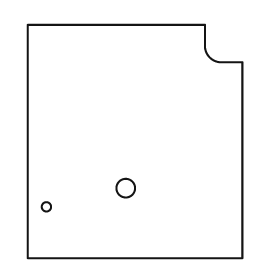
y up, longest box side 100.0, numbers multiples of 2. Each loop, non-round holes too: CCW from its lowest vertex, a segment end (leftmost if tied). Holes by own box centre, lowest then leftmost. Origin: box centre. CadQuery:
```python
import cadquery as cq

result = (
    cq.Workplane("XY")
    .moveTo(-46.0, -50.0)
    .lineTo(46.0, -50.0)
    .lineTo(46.0, 34.0)
    .lineTo(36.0, 34.0)
    .threePointArc((32.0, 36.0), (30.0, 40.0))
    .lineTo(30.0, 50.0)
    .lineTo(-46.0, 50.0)
    .close()
    .moveTo(-38.0, -28.0)
    .circle(2.0)
    .moveTo(-4.0, -20.0)
    .circle(4.0)
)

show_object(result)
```